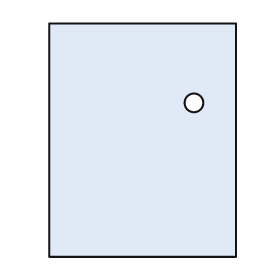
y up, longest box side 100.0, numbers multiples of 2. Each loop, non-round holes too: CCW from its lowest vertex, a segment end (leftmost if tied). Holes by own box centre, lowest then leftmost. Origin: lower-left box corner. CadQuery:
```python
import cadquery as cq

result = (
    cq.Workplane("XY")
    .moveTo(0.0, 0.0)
    .lineTo(80.0, 0.0)
    .lineTo(80.0, 100.0)
    .lineTo(0.0, 100.0)
    .close()
    .moveTo(62.0, 66.0)
    .circle(4.0)
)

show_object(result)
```